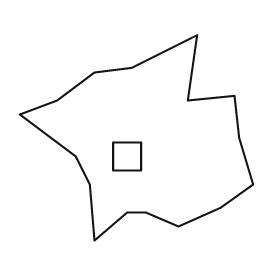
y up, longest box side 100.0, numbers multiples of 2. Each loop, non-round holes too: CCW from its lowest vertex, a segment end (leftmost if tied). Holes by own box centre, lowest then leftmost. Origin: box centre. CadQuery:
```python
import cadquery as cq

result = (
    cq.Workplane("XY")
    .moveTo(-18.0, -44.0)
    .lineTo(-4.0, -32.0)
    .lineTo(4.0, -32.0)
    .lineTo(18.0, -38.0)
    .lineTo(36.0, -30.0)
    .lineTo(50.0, -20.0)
    .lineTo(44.0, 0.0)
    .lineTo(42.0, 18.0)
    .lineTo(22.0, 16.0)
    .lineTo(26.0, 44.0)
    .lineTo(-2.0, 30.0)
    .lineTo(-18.0, 28.0)
    .lineTo(-34.0, 16.0)
    .lineTo(-50.0, 10.0)
    .lineTo(-26.0, -8.0)
    .lineTo(-20.0, -20.0)
    .close()
    .moveTo(-10.0, -14.0)
    .lineTo(2.0, -14.0)
    .lineTo(2.0, -2.0)
    .lineTo(-10.0, -2.0)
    .close()
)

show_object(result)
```